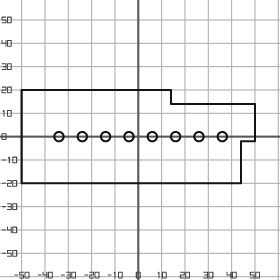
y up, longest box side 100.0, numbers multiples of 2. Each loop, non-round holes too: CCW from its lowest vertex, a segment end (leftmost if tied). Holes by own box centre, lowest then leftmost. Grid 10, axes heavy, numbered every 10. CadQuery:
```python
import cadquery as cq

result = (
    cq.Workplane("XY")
    .moveTo(-50.0, -20.0)
    .lineTo(44.0, -20.0)
    .lineTo(44.0, -2.0)
    .lineTo(50.0, -2.0)
    .lineTo(50.0, 14.0)
    .lineTo(14.0, 14.0)
    .lineTo(14.0, 20.0)
    .lineTo(-50.0, 20.0)
    .close()
    .moveTo(-34.0, 0.0)
    .circle(2.0)
    .moveTo(-24.0, 0.0)
    .circle(2.0)
    .moveTo(-14.0, 0.0)
    .circle(2.0)
    .moveTo(-4.0, 0.0)
    .circle(2.0)
    .moveTo(6.0, 0.0)
    .circle(2.0)
    .moveTo(16.0, 0.0)
    .circle(2.0)
    .moveTo(26.0, 0.0)
    .circle(2.0)
    .moveTo(36.0, 0.0)
    .circle(2.0)
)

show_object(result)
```